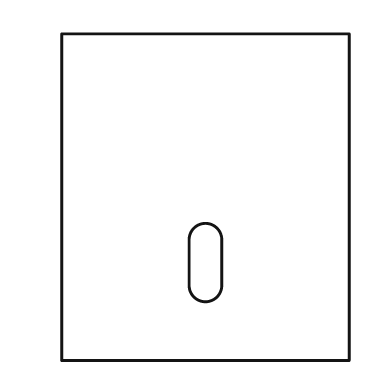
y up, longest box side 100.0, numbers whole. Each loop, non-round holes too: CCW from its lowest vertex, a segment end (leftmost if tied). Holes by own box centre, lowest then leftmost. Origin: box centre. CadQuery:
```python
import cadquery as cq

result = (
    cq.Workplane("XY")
    .moveTo(-44.0, -50.0)
    .lineTo(44.0, -50.0)
    .lineTo(44.0, 50.0)
    .lineTo(-44.0, 50.0)
    .close()
    .moveTo(-5.0, -27.0)
    .threePointArc((0.0, -32.0), (5.0, -27.0))
    .lineTo(5.0, -13.0)
    .threePointArc((0.0, -8.0), (-5.0, -13.0))
    .close()
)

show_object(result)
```